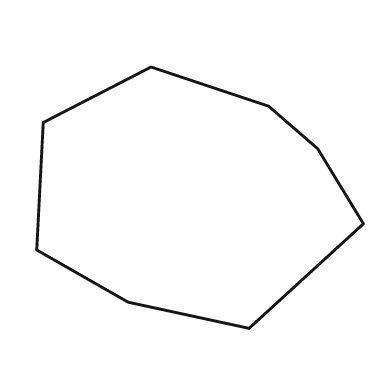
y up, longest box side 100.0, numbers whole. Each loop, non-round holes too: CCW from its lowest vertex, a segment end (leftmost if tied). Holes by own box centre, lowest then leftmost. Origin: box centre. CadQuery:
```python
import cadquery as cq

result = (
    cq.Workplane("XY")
    .moveTo(15.0, -40.0)
    .lineTo(50.0, -8.0)
    .lineTo(36.0, 15.0)
    .lineTo(21.0, 28.0)
    .lineTo(-15.0, 40.0)
    .lineTo(-48.0, 23.0)
    .lineTo(-50.0, -16.0)
    .lineTo(-22.0, -32.0)
    .close()
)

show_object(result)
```